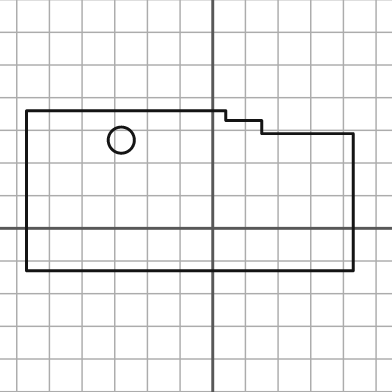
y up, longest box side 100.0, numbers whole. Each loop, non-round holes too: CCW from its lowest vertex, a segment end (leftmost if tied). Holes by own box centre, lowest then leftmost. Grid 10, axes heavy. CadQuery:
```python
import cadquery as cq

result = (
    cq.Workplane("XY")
    .moveTo(-57.0, -13.0)
    .lineTo(43.0, -13.0)
    .lineTo(43.0, 29.0)
    .lineTo(15.0, 29.0)
    .lineTo(15.0, 33.0)
    .lineTo(4.0, 33.0)
    .lineTo(4.0, 36.0)
    .lineTo(-57.0, 36.0)
    .close()
    .moveTo(-28.0, 27.0)
    .circle(4.0)
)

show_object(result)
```